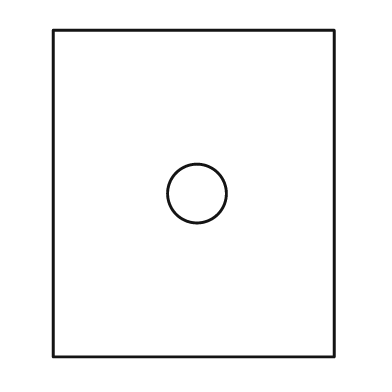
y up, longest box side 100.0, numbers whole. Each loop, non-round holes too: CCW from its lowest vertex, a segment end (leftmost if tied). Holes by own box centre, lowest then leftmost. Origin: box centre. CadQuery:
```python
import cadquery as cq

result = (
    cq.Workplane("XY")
    .moveTo(-43.0, -50.0)
    .lineTo(43.0, -50.0)
    .lineTo(43.0, 50.0)
    .lineTo(-43.0, 50.0)
    .close()
    .moveTo(1.0, 0.0)
    .circle(9.0)
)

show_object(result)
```